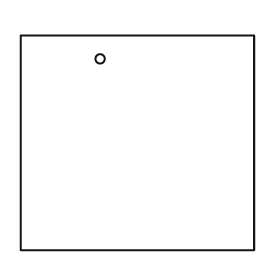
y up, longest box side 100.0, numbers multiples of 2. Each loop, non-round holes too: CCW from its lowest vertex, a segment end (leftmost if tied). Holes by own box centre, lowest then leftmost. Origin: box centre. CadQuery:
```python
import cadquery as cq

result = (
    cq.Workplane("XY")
    .moveTo(-50.0, -46.0)
    .lineTo(50.0, -46.0)
    .lineTo(50.0, 46.0)
    .lineTo(-50.0, 46.0)
    .close()
    .moveTo(-16.0, 36.0)
    .circle(2.0)
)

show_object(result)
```